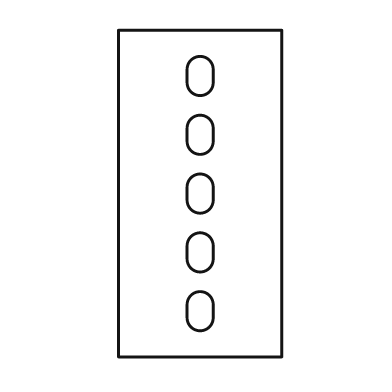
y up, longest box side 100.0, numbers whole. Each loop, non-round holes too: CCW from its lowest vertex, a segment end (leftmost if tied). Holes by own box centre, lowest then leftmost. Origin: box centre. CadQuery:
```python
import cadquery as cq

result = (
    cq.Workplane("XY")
    .moveTo(-25.0, -50.0)
    .lineTo(25.0, -50.0)
    .lineTo(25.0, 50.0)
    .lineTo(-25.0, 50.0)
    .close()
    .moveTo(-4.0, -38.0)
    .threePointArc((0.0, -42.0), (4.0, -38.0))
    .lineTo(4.0, -34.0)
    .threePointArc((0.0, -30.0), (-4.0, -34.0))
    .close()
    .moveTo(-4.0, -20.0)
    .threePointArc((0.0, -24.0), (4.0, -20.0))
    .lineTo(4.0, -16.0)
    .threePointArc((0.0, -12.0), (-4.0, -16.0))
    .close()
    .moveTo(-4.0, -2.0)
    .threePointArc((0.0, -6.0), (4.0, -2.0))
    .lineTo(4.0, 2.0)
    .threePointArc((0.0, 6.0), (-4.0, 2.0))
    .close()
    .moveTo(-4.0, 16.0)
    .threePointArc((0.0, 12.0), (4.0, 16.0))
    .lineTo(4.0, 20.0)
    .threePointArc((0.0, 24.0), (-4.0, 20.0))
    .close()
    .moveTo(-4.0, 34.0)
    .threePointArc((0.0, 30.0), (4.0, 34.0))
    .lineTo(4.0, 38.0)
    .threePointArc((0.0, 42.0), (-4.0, 38.0))
    .close()
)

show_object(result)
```